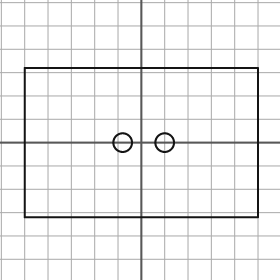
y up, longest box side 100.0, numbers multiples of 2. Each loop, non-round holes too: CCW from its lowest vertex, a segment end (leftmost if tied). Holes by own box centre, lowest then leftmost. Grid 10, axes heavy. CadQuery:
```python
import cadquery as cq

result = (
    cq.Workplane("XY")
    .moveTo(-50.0, -32.0)
    .lineTo(50.0, -32.0)
    .lineTo(50.0, 32.0)
    .lineTo(-50.0, 32.0)
    .close()
    .moveTo(-8.0, 0.0)
    .circle(4.0)
    .moveTo(10.0, 0.0)
    .circle(4.0)
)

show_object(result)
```